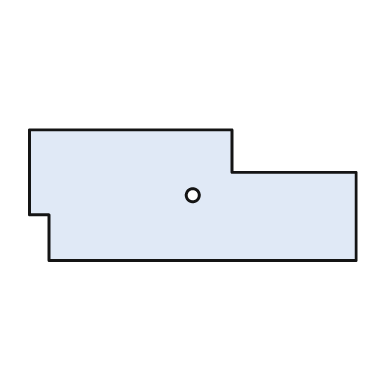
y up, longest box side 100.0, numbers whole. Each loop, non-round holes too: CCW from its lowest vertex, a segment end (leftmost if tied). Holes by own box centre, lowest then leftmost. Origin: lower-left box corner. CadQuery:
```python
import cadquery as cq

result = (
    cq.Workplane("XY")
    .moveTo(6.0, 0.0)
    .lineTo(100.0, 0.0)
    .lineTo(100.0, 27.0)
    .lineTo(62.0, 27.0)
    .lineTo(62.0, 40.0)
    .lineTo(0.0, 40.0)
    .lineTo(0.0, 14.0)
    .lineTo(6.0, 14.0)
    .close()
    .moveTo(50.0, 20.0)
    .circle(2.0)
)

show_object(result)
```